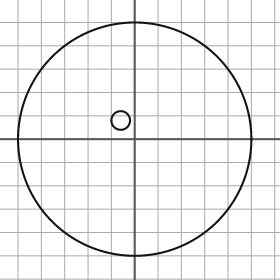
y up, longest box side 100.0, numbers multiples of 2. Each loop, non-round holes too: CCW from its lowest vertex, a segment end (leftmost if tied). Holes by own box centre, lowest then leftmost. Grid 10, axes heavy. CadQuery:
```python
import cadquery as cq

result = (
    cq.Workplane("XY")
    .moveTo(0.0, 0.0)
    .circle(50.0)
    .moveTo(-6.0, 8.0)
    .circle(4.0)
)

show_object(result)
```